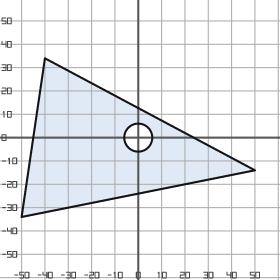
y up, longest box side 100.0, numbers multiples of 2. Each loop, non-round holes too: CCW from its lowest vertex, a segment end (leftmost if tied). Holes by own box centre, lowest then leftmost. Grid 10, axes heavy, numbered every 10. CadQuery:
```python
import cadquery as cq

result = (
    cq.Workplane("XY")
    .moveTo(-50.0, -34.0)
    .lineTo(50.0, -14.0)
    .lineTo(-40.0, 34.0)
    .close()
    .moveTo(0.0, 0.0)
    .circle(6.0)
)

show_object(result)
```